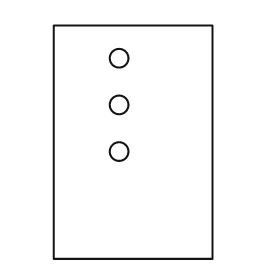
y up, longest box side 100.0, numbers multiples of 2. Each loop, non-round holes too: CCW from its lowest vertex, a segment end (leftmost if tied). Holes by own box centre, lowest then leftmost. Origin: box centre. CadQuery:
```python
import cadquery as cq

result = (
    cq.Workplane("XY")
    .moveTo(-34.0, -50.0)
    .lineTo(34.0, -50.0)
    .lineTo(34.0, 50.0)
    .lineTo(-34.0, 50.0)
    .close()
    .moveTo(-6.0, -4.0)
    .circle(4.0)
    .moveTo(-6.0, 16.0)
    .circle(4.0)
    .moveTo(-6.0, 36.0)
    .circle(4.0)
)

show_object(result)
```